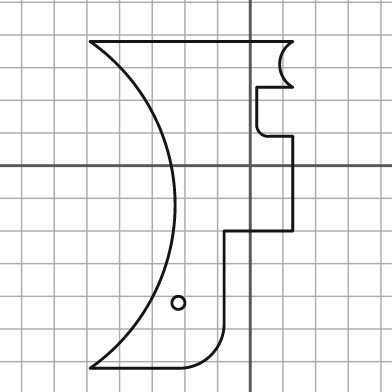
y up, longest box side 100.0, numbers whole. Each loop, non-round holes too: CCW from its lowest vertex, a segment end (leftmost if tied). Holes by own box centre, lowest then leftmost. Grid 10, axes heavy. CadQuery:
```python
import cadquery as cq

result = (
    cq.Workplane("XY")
    .moveTo(-49.0, -62.0)
    .lineTo(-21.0, -62.0)
    .threePointArc((-12.0, -58.0), (-8.0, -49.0))
    .lineTo(-8.0, -20.0)
    .lineTo(13.0, -20.0)
    .lineTo(13.0, 9.0)
    .lineTo(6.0, 9.0)
    .threePointArc((3.0, 10.0), (2.0, 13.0))
    .lineTo(2.0, 24.0)
    .lineTo(13.0, 24.0)
    .threePointArc((9.0, 31.0), (13.0, 38.0))
    .lineTo(-49.0, 38.0)
    .threePointArc((-23.0, -12.0), (-49.0, -62.0))
    .close()
    .moveTo(-22.0, -42.0)
    .circle(2.0)
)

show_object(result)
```